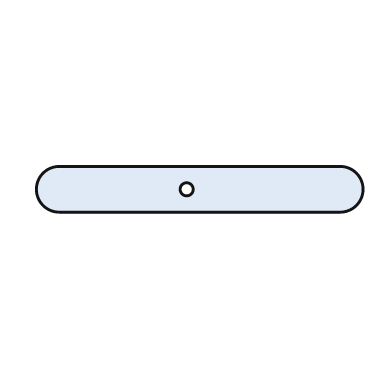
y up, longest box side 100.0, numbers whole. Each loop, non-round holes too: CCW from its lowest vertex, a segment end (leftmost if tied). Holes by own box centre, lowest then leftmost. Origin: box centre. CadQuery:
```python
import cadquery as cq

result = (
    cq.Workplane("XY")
    .moveTo(-43.0, -7.0)
    .lineTo(43.0, -7.0)
    .threePointArc((50.0, 0.0), (43.0, 7.0))
    .lineTo(-43.0, 7.0)
    .threePointArc((-50.0, 0.0), (-43.0, -7.0))
    .close()
    .moveTo(-4.0, 0.0)
    .circle(2.0)
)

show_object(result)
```